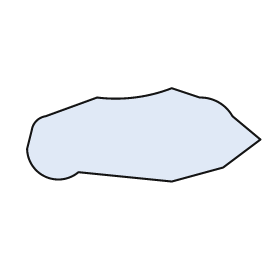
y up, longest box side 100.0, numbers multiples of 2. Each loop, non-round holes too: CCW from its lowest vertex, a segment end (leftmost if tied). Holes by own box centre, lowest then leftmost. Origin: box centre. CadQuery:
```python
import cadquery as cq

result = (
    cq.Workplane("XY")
    .moveTo(12.0, -20.0)
    .lineTo(34.0, -14.0)
    .lineTo(50.0, -2.0)
    .lineTo(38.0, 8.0)
    .threePointArc((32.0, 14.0), (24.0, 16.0))
    .lineTo(12.0, 20.0)
    .threePointArc((-4.0, 16.0), (-20.0, 16.0))
    .lineTo(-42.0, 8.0)
    .threePointArc((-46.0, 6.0), (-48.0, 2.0))
    .lineTo(-50.0, -6.0)
    .threePointArc((-42.0, -18.0), (-28.0, -16.0))
    .close()
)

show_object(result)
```